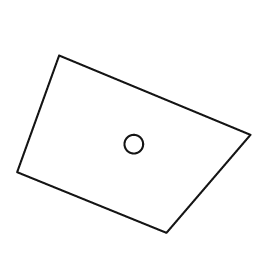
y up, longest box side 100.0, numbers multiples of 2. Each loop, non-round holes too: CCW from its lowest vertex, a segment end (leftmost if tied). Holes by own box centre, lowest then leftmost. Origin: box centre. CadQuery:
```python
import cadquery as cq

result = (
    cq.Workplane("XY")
    .moveTo(14.0, -38.0)
    .lineTo(50.0, 4.0)
    .lineTo(-32.0, 38.0)
    .lineTo(-50.0, -12.0)
    .close()
    .moveTo(0.0, 0.0)
    .circle(4.0)
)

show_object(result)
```